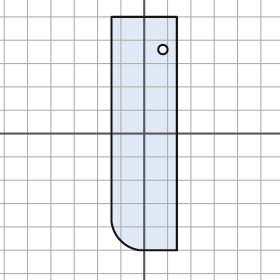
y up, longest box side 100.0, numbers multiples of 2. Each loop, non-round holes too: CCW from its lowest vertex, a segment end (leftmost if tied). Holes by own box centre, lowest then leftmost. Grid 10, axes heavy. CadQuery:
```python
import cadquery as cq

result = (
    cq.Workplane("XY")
    .moveTo(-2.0, -50.0)
    .lineTo(14.0, -50.0)
    .lineTo(14.0, 50.0)
    .lineTo(-14.0, 50.0)
    .lineTo(-14.0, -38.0)
    .threePointArc((-10.0, -46.0), (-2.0, -50.0))
    .close()
    .moveTo(8.0, 36.0)
    .circle(2.0)
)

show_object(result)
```